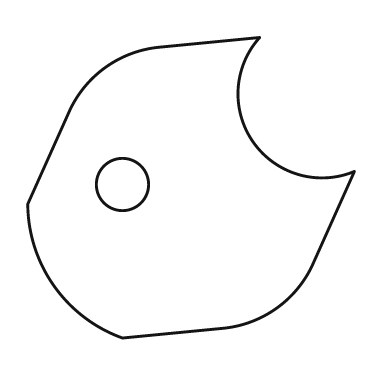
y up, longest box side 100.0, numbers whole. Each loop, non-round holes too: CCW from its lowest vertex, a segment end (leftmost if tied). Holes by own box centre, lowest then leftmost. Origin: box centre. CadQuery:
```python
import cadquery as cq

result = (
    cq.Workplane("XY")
    .moveTo(-21.0, -46.0)
    .lineTo(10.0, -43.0)
    .threePointArc((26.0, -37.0), (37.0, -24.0))
    .lineTo(50.0, 5.0)
    .threePointArc((19.0, 14.0), (21.0, 46.0))
    .lineTo(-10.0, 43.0)
    .threePointArc((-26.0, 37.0), (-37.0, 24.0))
    .lineTo(-50.0, -5.0)
    .threePointArc((-42.0, -30.0), (-21.0, -46.0))
    .close()
    .moveTo(-21.0, 1.0)
    .circle(8.0)
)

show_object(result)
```